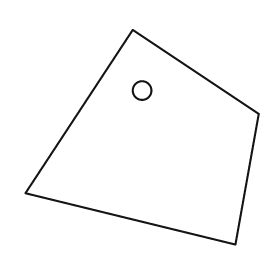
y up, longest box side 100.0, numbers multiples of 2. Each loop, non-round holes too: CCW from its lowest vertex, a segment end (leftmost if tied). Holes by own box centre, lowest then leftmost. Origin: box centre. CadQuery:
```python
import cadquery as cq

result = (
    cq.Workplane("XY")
    .moveTo(40.0, -46.0)
    .lineTo(50.0, 10.0)
    .lineTo(-4.0, 46.0)
    .lineTo(-50.0, -24.0)
    .close()
    .moveTo(0.0, 20.0)
    .circle(4.0)
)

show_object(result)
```